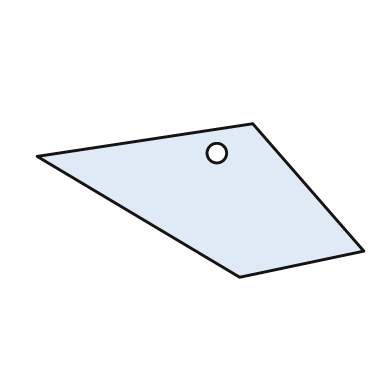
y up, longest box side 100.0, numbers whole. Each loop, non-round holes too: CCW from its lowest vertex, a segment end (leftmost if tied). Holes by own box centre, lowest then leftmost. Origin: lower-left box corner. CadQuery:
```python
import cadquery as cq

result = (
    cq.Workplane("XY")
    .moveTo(62.0, 0.0)
    .lineTo(100.0, 8.0)
    .lineTo(66.0, 47.0)
    .lineTo(0.0, 37.0)
    .close()
    .moveTo(55.0, 38.0)
    .circle(3.0)
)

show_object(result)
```